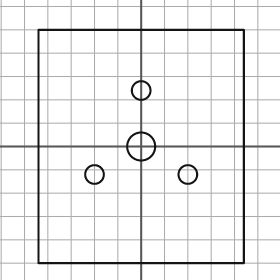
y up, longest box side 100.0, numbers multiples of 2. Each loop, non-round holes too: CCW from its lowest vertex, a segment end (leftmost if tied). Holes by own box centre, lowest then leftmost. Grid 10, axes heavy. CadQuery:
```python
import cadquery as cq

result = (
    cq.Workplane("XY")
    .moveTo(-44.0, -50.0)
    .lineTo(44.0, -50.0)
    .lineTo(44.0, 50.0)
    .lineTo(-44.0, 50.0)
    .close()
    .moveTo(-20.0, -12.0)
    .circle(4.0)
    .moveTo(20.0, -12.0)
    .circle(4.0)
    .moveTo(0.0, 0.0)
    .circle(6.0)
    .moveTo(0.0, 24.0)
    .circle(4.0)
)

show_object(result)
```